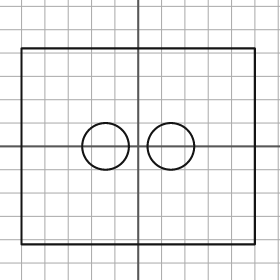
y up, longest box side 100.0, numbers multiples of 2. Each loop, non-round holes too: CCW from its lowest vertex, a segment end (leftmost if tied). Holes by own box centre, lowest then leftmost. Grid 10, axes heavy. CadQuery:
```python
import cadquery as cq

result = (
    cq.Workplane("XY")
    .moveTo(-50.0, -42.0)
    .lineTo(50.0, -42.0)
    .lineTo(50.0, 42.0)
    .lineTo(-50.0, 42.0)
    .close()
    .moveTo(-14.0, 0.0)
    .circle(10.0)
    .moveTo(14.0, 0.0)
    .circle(10.0)
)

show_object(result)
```